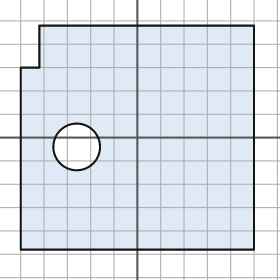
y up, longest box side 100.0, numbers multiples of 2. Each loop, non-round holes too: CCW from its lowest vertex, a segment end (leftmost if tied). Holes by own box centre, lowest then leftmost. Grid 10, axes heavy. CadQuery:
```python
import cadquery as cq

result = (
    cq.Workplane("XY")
    .moveTo(-50.0, -48.0)
    .lineTo(50.0, -48.0)
    .lineTo(50.0, 48.0)
    .lineTo(-42.0, 48.0)
    .lineTo(-42.0, 30.0)
    .lineTo(-50.0, 30.0)
    .close()
    .moveTo(-26.0, -4.0)
    .circle(10.0)
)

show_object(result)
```